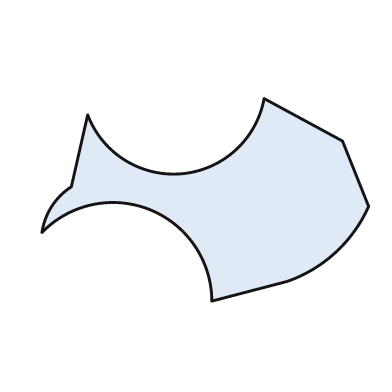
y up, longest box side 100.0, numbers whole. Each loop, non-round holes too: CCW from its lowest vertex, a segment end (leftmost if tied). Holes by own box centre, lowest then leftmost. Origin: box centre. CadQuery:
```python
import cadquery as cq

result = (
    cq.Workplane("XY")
    .moveTo(2.0, -31.0)
    .lineTo(25.0, -25.0)
    .threePointArc((40.0, -16.0), (50.0, -2.0))
    .lineTo(42.0, 18.0)
    .lineTo(18.0, 31.0)
    .threePointArc((-7.0, 8.0), (-36.0, 26.0))
    .lineTo(-41.0, 4.0)
    .threePointArc((-47.0, -2.0), (-50.0, -10.0))
    .threePointArc((-17.0, -3.0), (2.0, -31.0))
    .close()
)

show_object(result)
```